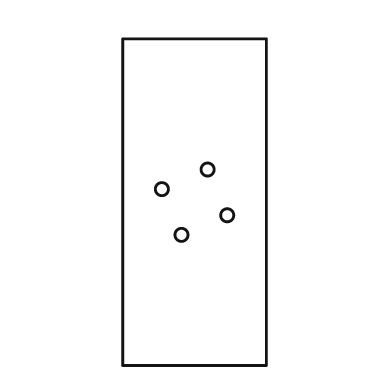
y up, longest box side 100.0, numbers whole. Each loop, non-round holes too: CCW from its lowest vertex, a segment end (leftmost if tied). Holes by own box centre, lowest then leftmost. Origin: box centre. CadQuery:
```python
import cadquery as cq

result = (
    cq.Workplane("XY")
    .moveTo(-22.0, -50.0)
    .lineTo(22.0, -50.0)
    .lineTo(22.0, 50.0)
    .lineTo(-22.0, 50.0)
    .close()
    .moveTo(-4.0, -10.0)
    .circle(2.0)
    .moveTo(10.0, -4.0)
    .circle(2.0)
    .moveTo(-10.0, 4.0)
    .circle(2.0)
    .moveTo(4.0, 10.0)
    .circle(2.0)
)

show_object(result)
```